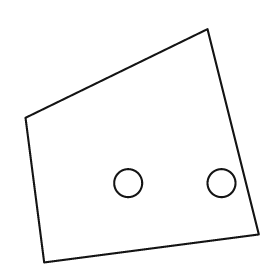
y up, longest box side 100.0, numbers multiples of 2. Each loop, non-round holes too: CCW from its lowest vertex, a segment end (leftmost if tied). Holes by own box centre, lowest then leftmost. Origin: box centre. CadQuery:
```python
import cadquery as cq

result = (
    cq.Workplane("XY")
    .moveTo(-42.0, -50.0)
    .lineTo(50.0, -38.0)
    .lineTo(28.0, 50.0)
    .lineTo(-50.0, 12.0)
    .close()
    .moveTo(-6.0, -16.0)
    .circle(6.0)
    .moveTo(34.0, -16.0)
    .circle(6.0)
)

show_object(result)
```